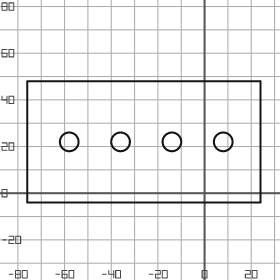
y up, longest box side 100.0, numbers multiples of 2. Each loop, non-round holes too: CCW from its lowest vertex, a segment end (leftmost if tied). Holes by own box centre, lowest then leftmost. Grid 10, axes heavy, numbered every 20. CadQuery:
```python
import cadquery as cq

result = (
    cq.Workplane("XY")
    .moveTo(-76.0, -4.0)
    .lineTo(24.0, -4.0)
    .lineTo(24.0, 48.0)
    .lineTo(-76.0, 48.0)
    .close()
    .moveTo(-58.0, 22.0)
    .circle(4.0)
    .moveTo(-36.0, 22.0)
    .circle(4.0)
    .moveTo(-14.0, 22.0)
    .circle(4.0)
    .moveTo(8.0, 22.0)
    .circle(4.0)
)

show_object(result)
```